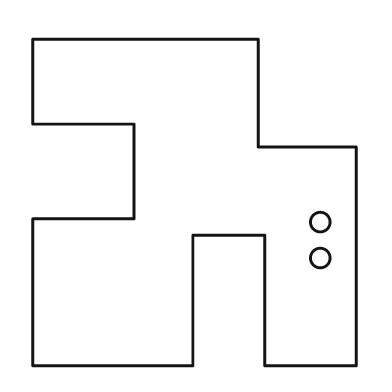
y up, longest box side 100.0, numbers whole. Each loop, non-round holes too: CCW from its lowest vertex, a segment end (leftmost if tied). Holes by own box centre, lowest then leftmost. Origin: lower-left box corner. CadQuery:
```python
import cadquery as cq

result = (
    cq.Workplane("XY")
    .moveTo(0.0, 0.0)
    .lineTo(49.0, 0.0)
    .lineTo(49.0, 40.0)
    .lineTo(71.0, 40.0)
    .lineTo(71.0, 0.0)
    .lineTo(99.0, 0.0)
    .lineTo(99.0, 67.0)
    .lineTo(69.0, 67.0)
    .lineTo(69.0, 100.0)
    .lineTo(0.0, 100.0)
    .lineTo(0.0, 74.0)
    .lineTo(31.0, 74.0)
    .lineTo(31.0, 45.0)
    .lineTo(0.0, 45.0)
    .close()
    .moveTo(88.0, 33.0)
    .circle(3.0)
    .moveTo(88.0, 44.0)
    .circle(3.0)
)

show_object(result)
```